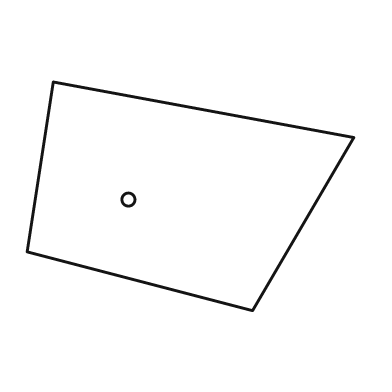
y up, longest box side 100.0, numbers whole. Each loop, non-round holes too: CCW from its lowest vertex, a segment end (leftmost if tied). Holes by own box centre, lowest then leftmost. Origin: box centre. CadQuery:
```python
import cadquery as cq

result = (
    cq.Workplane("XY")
    .moveTo(19.0, -35.0)
    .lineTo(50.0, 18.0)
    .lineTo(-42.0, 35.0)
    .lineTo(-50.0, -17.0)
    .close()
    .moveTo(-19.0, -1.0)
    .circle(2.0)
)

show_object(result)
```